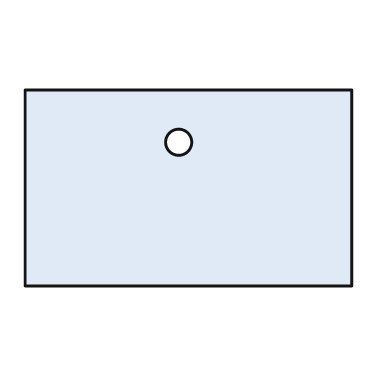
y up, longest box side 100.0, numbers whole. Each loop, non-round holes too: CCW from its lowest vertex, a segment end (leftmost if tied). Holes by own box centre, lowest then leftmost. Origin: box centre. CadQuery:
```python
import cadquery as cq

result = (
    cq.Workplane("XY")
    .moveTo(-50.0, -30.0)
    .lineTo(50.0, -30.0)
    .lineTo(50.0, 30.0)
    .lineTo(-50.0, 30.0)
    .close()
    .moveTo(-3.0, 14.0)
    .circle(4.0)
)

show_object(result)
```